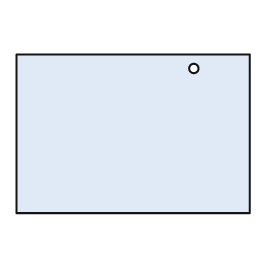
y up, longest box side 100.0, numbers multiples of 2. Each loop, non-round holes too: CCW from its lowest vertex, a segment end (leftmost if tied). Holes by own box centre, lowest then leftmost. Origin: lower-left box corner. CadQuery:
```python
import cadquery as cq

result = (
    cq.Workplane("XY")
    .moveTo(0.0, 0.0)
    .lineTo(100.0, 0.0)
    .lineTo(100.0, 68.0)
    .lineTo(0.0, 68.0)
    .close()
    .moveTo(76.0, 62.0)
    .circle(2.0)
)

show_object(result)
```